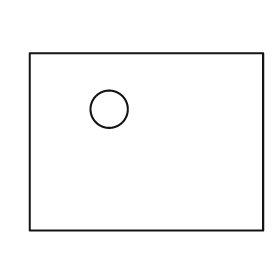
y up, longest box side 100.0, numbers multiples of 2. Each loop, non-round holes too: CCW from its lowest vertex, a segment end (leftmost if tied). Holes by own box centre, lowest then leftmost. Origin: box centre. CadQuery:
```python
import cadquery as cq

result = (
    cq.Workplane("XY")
    .moveTo(-50.0, -38.0)
    .lineTo(50.0, -38.0)
    .lineTo(50.0, 38.0)
    .lineTo(-50.0, 38.0)
    .close()
    .moveTo(-16.0, 14.0)
    .circle(8.0)
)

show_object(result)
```